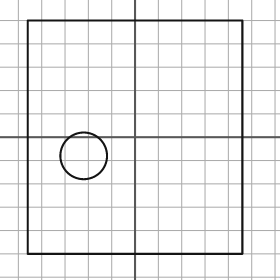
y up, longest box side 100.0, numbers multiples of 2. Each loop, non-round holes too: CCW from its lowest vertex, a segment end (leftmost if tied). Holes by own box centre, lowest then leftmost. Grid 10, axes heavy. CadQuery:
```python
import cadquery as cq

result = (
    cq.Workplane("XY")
    .moveTo(-46.0, -50.0)
    .lineTo(46.0, -50.0)
    .lineTo(46.0, 50.0)
    .lineTo(-46.0, 50.0)
    .close()
    .moveTo(-22.0, -8.0)
    .circle(10.0)
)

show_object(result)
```